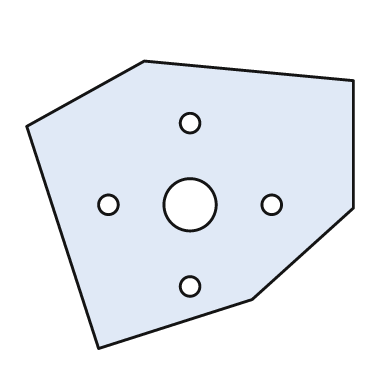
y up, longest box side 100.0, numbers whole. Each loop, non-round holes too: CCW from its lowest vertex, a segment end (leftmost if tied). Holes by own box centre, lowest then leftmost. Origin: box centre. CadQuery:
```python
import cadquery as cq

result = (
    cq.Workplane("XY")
    .moveTo(-28.0, -44.0)
    .lineTo(19.0, -29.0)
    .lineTo(50.0, -1.0)
    .lineTo(50.0, 38.0)
    .lineTo(-14.0, 44.0)
    .lineTo(-50.0, 24.0)
    .close()
    .moveTo(0.0, -25.0)
    .circle(3.0)
    .moveTo(-25.0, 0.0)
    .circle(3.0)
    .moveTo(0.0, 0.0)
    .circle(8.0)
    .moveTo(25.0, 0.0)
    .circle(3.0)
    .moveTo(0.0, 25.0)
    .circle(3.0)
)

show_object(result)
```